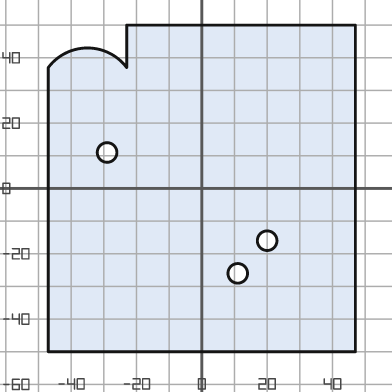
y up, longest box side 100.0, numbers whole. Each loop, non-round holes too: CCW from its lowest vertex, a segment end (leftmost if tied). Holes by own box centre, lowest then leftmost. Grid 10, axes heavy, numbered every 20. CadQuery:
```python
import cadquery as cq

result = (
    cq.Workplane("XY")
    .moveTo(-47.0, -50.0)
    .lineTo(47.0, -50.0)
    .lineTo(47.0, 50.0)
    .lineTo(-23.0, 50.0)
    .lineTo(-23.0, 37.0)
    .threePointArc((-35.0, 43.0), (-47.0, 37.0))
    .close()
    .moveTo(11.0, -26.0)
    .circle(3.0)
    .moveTo(20.0, -16.0)
    .circle(3.0)
    .moveTo(-29.0, 11.0)
    .circle(3.0)
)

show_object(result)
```